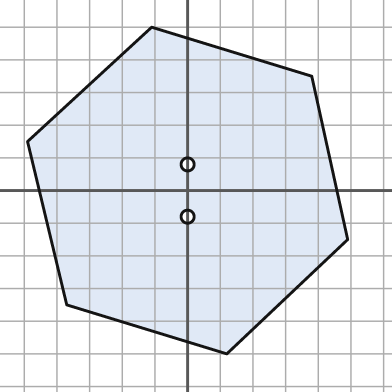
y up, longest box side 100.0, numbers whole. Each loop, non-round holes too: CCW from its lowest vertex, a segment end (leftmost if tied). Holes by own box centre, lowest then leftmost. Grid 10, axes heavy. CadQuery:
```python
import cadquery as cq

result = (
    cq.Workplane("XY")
    .moveTo(12.0, -50.0)
    .lineTo(49.0, -15.0)
    .lineTo(38.0, 35.0)
    .lineTo(-11.0, 50.0)
    .lineTo(-49.0, 15.0)
    .lineTo(-37.0, -35.0)
    .close()
    .moveTo(0.0, -8.0)
    .circle(2.0)
    .moveTo(0.0, 8.0)
    .circle(2.0)
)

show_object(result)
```